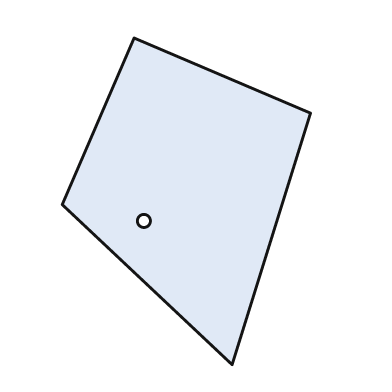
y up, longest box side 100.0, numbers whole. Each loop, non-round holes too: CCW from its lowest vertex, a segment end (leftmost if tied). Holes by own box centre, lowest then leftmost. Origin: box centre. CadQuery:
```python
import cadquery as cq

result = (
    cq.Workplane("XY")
    .moveTo(14.0, -50.0)
    .lineTo(38.0, 27.0)
    .lineTo(-16.0, 50.0)
    .lineTo(-38.0, -1.0)
    .close()
    .moveTo(-13.0, -6.0)
    .circle(2.0)
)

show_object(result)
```